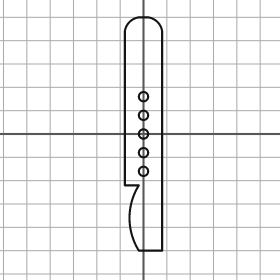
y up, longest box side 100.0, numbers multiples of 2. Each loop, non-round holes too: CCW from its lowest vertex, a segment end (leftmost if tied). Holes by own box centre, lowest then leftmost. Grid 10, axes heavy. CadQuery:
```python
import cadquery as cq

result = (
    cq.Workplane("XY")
    .moveTo(-2.0, -50.0)
    .lineTo(8.0, -50.0)
    .lineTo(8.0, 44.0)
    .threePointArc((6.0, 48.0), (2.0, 50.0))
    .lineTo(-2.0, 50.0)
    .threePointArc((-6.0, 48.0), (-8.0, 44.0))
    .lineTo(-8.0, -22.0)
    .lineTo(-2.0, -22.0)
    .threePointArc((-6.0, -36.0), (-2.0, -50.0))
    .close()
    .moveTo(0.0, -16.0)
    .circle(2.0)
    .moveTo(0.0, -8.0)
    .circle(2.0)
    .moveTo(0.0, 0.0)
    .circle(2.0)
    .moveTo(0.0, 8.0)
    .circle(2.0)
    .moveTo(0.0, 16.0)
    .circle(2.0)
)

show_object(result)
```